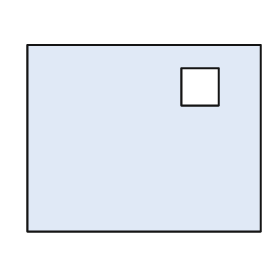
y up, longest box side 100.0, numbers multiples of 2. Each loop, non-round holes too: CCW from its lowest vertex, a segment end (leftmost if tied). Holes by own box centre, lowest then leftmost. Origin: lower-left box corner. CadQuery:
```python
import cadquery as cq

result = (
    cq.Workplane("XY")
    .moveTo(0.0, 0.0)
    .lineTo(100.0, 0.0)
    .lineTo(100.0, 80.0)
    .lineTo(0.0, 80.0)
    .close()
    .moveTo(66.0, 54.0)
    .lineTo(82.0, 54.0)
    .lineTo(82.0, 70.0)
    .lineTo(66.0, 70.0)
    .close()
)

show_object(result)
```